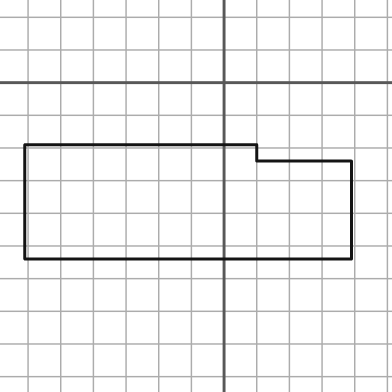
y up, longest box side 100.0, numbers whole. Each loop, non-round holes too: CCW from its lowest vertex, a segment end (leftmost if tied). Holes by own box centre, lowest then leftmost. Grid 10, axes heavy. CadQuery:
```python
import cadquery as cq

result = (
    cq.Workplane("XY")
    .moveTo(-61.0, -54.0)
    .lineTo(39.0, -54.0)
    .lineTo(39.0, -24.0)
    .lineTo(10.0, -24.0)
    .lineTo(10.0, -19.0)
    .lineTo(-61.0, -19.0)
    .close()
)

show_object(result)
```